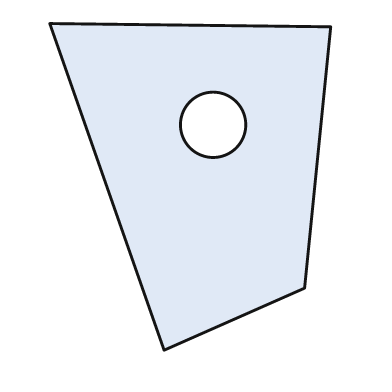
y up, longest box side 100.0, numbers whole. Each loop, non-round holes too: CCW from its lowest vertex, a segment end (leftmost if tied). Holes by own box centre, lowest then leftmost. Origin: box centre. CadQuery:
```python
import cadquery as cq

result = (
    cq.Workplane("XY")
    .moveTo(-8.0, -50.0)
    .lineTo(35.0, -31.0)
    .lineTo(43.0, 49.0)
    .lineTo(-43.0, 50.0)
    .close()
    .moveTo(7.0, 19.0)
    .circle(10.0)
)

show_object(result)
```